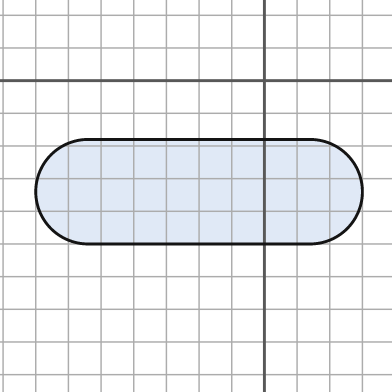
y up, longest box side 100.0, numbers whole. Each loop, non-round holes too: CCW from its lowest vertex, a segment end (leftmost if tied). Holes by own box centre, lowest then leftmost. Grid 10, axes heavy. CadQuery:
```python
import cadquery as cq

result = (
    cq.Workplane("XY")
    .moveTo(-54.0, -50.0)
    .lineTo(14.0, -50.0)
    .threePointArc((30.0, -34.0), (14.0, -18.0))
    .lineTo(-54.0, -18.0)
    .threePointArc((-70.0, -34.0), (-54.0, -50.0))
    .close()
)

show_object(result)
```